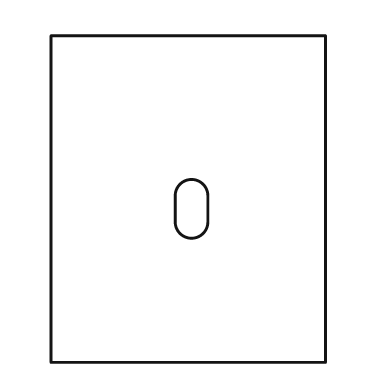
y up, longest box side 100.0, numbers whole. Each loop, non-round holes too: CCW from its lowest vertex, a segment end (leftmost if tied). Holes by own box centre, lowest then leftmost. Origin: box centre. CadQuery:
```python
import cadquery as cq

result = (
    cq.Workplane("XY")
    .moveTo(-42.0, -50.0)
    .lineTo(42.0, -50.0)
    .lineTo(42.0, 50.0)
    .lineTo(-42.0, 50.0)
    .close()
    .moveTo(-4.0, -7.0)
    .threePointArc((1.0, -12.0), (6.0, -7.0))
    .lineTo(6.0, 1.0)
    .threePointArc((1.0, 6.0), (-4.0, 1.0))
    .close()
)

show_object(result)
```